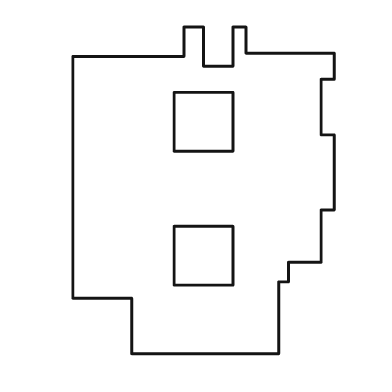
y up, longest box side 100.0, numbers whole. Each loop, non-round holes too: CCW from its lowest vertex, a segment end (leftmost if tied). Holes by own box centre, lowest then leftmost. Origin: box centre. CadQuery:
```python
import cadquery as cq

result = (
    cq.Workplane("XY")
    .moveTo(-22.0, -50.0)
    .lineTo(23.0, -50.0)
    .lineTo(23.0, -28.0)
    .lineTo(26.0, -28.0)
    .lineTo(26.0, -22.0)
    .lineTo(36.0, -22.0)
    .lineTo(36.0, -6.0)
    .lineTo(40.0, -6.0)
    .lineTo(40.0, 17.0)
    .lineTo(36.0, 17.0)
    .lineTo(36.0, 34.0)
    .lineTo(40.0, 34.0)
    .lineTo(40.0, 42.0)
    .lineTo(13.0, 42.0)
    .lineTo(13.0, 50.0)
    .lineTo(9.0, 50.0)
    .lineTo(9.0, 38.0)
    .lineTo(0.0, 38.0)
    .lineTo(0.0, 50.0)
    .lineTo(-6.0, 50.0)
    .lineTo(-6.0, 41.0)
    .lineTo(-40.0, 41.0)
    .lineTo(-40.0, -33.0)
    .lineTo(-22.0, -33.0)
    .close()
    .moveTo(-9.0, -29.0)
    .lineTo(9.0, -29.0)
    .lineTo(9.0, -11.0)
    .lineTo(-9.0, -11.0)
    .close()
    .moveTo(-9.0, 12.0)
    .lineTo(9.0, 12.0)
    .lineTo(9.0, 30.0)
    .lineTo(-9.0, 30.0)
    .close()
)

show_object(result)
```